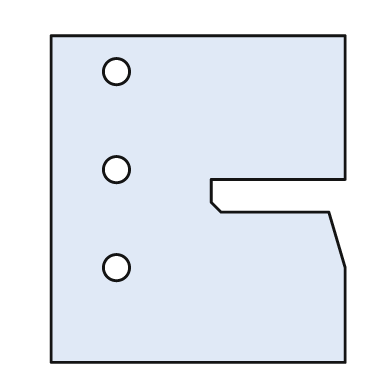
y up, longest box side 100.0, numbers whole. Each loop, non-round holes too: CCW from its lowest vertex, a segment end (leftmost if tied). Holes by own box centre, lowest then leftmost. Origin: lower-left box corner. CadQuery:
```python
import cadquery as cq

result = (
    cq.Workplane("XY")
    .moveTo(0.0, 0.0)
    .lineTo(90.0, 0.0)
    .lineTo(90.0, 29.0)
    .lineTo(85.0, 46.0)
    .lineTo(52.0, 46.0)
    .lineTo(49.0, 49.0)
    .lineTo(49.0, 56.0)
    .lineTo(90.0, 56.0)
    .lineTo(90.0, 100.0)
    .lineTo(0.0, 100.0)
    .close()
    .moveTo(20.0, 29.0)
    .circle(4.0)
    .moveTo(20.0, 59.0)
    .circle(4.0)
    .moveTo(20.0, 89.0)
    .circle(4.0)
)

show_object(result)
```